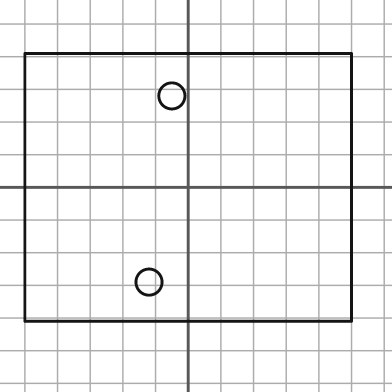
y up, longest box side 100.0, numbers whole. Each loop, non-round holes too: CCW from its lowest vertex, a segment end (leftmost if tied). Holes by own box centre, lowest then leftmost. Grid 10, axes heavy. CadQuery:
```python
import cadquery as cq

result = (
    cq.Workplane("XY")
    .moveTo(-50.0, -41.0)
    .lineTo(50.0, -41.0)
    .lineTo(50.0, 41.0)
    .lineTo(-50.0, 41.0)
    .close()
    .moveTo(-12.0, -29.0)
    .circle(4.0)
    .moveTo(-5.0, 28.0)
    .circle(4.0)
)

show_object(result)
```